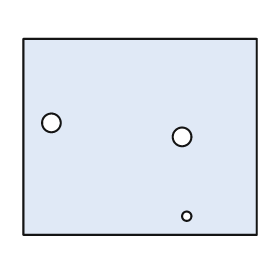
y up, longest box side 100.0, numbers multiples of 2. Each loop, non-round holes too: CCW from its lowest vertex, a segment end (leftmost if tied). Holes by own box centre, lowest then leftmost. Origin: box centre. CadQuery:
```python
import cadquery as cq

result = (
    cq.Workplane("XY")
    .moveTo(-50.0, -42.0)
    .lineTo(50.0, -42.0)
    .lineTo(50.0, 42.0)
    .lineTo(-50.0, 42.0)
    .close()
    .moveTo(20.0, -34.0)
    .circle(2.0)
    .moveTo(18.0, 0.0)
    .circle(4.0)
    .moveTo(-38.0, 6.0)
    .circle(4.0)
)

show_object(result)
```